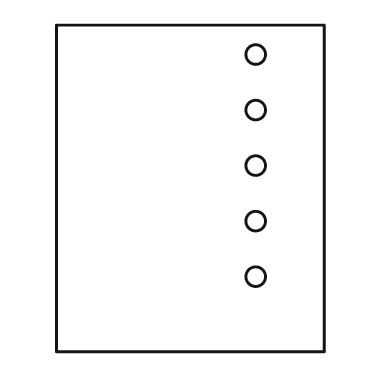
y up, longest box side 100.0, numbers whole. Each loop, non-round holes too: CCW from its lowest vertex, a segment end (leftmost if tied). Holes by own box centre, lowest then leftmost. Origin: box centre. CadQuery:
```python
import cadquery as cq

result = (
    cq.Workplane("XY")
    .moveTo(-41.0, -50.0)
    .lineTo(41.0, -50.0)
    .lineTo(41.0, 50.0)
    .lineTo(-41.0, 50.0)
    .close()
    .moveTo(20.0, -27.0)
    .circle(3.0)
    .moveTo(20.0, -10.0)
    .circle(3.0)
    .moveTo(20.0, 7.0)
    .circle(3.0)
    .moveTo(20.0, 24.0)
    .circle(3.0)
    .moveTo(20.0, 41.0)
    .circle(3.0)
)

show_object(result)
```